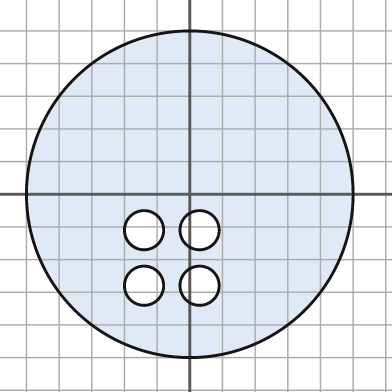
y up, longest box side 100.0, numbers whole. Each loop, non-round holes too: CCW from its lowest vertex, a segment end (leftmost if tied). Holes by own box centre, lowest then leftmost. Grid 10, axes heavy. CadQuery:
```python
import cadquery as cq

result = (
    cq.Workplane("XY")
    .moveTo(0.0, 0.0)
    .circle(50.0)
    .moveTo(-14.0, -28.0)
    .circle(6.0)
    .moveTo(3.0, -28.0)
    .circle(6.0)
    .moveTo(-14.0, -11.0)
    .circle(6.0)
    .moveTo(3.0, -11.0)
    .circle(6.0)
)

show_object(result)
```